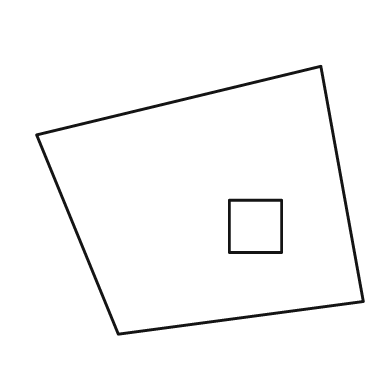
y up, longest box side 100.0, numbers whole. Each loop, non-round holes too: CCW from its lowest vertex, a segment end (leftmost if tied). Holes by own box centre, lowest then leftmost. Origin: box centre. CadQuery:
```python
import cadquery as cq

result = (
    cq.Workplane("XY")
    .moveTo(-25.0, -41.0)
    .lineTo(50.0, -31.0)
    .lineTo(37.0, 41.0)
    .lineTo(-50.0, 20.0)
    .close()
    .moveTo(9.0, -16.0)
    .lineTo(25.0, -16.0)
    .lineTo(25.0, 0.0)
    .lineTo(9.0, 0.0)
    .close()
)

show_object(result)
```